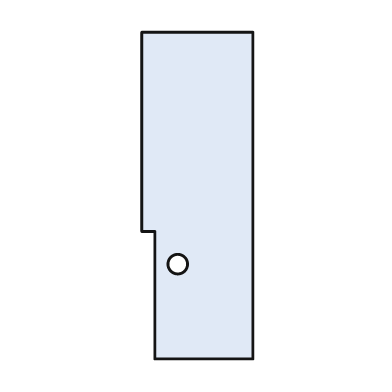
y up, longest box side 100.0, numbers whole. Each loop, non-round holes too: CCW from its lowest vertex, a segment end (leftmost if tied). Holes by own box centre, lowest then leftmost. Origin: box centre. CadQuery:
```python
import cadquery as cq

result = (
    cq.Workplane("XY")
    .moveTo(-13.0, -50.0)
    .lineTo(17.0, -50.0)
    .lineTo(17.0, 50.0)
    .lineTo(-17.0, 50.0)
    .lineTo(-17.0, -11.0)
    .lineTo(-13.0, -11.0)
    .close()
    .moveTo(-6.0, -21.0)
    .circle(3.0)
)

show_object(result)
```